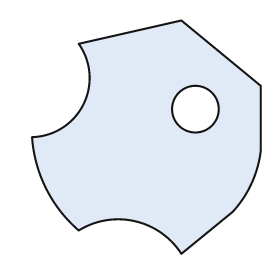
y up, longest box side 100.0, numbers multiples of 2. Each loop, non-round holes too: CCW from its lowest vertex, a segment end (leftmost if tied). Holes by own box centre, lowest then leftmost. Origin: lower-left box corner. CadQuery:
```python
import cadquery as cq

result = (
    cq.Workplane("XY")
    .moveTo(64.0, 0.0)
    .lineTo(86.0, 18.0)
    .threePointArc((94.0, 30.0), (98.0, 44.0))
    .lineTo(98.0, 72.0)
    .lineTo(64.0, 100.0)
    .lineTo(20.0, 90.0)
    .threePointArc((22.0, 64.0), (0.0, 50.0))
    .threePointArc((6.0, 28.0), (20.0, 10.0))
    .threePointArc((44.0, 14.0), (64.0, 0.0))
    .close()
    .moveTo(70.0, 62.0)
    .circle(10.0)
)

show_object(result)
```